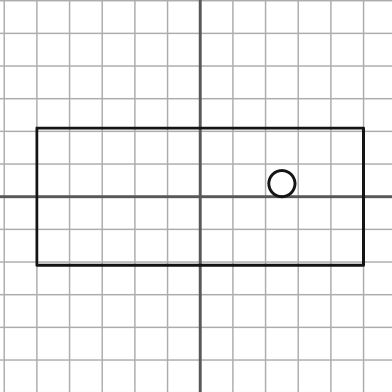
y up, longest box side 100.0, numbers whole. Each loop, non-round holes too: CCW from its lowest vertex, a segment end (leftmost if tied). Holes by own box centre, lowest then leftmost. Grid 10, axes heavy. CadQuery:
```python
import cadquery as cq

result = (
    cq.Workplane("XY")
    .moveTo(-50.0, -21.0)
    .lineTo(50.0, -21.0)
    .lineTo(50.0, 21.0)
    .lineTo(-50.0, 21.0)
    .close()
    .moveTo(25.0, 4.0)
    .circle(4.0)
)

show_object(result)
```